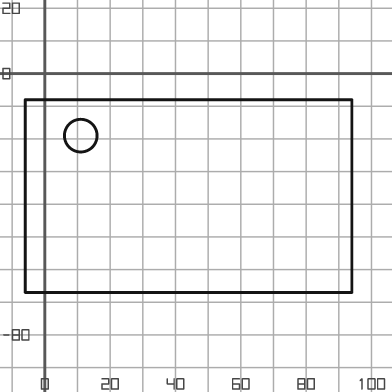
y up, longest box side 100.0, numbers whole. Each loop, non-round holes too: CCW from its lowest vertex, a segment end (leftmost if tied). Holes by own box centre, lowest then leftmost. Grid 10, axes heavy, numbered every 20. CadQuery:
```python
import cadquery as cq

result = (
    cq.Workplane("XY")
    .moveTo(-6.0, -67.0)
    .lineTo(94.0, -67.0)
    .lineTo(94.0, -8.0)
    .lineTo(-6.0, -8.0)
    .close()
    .moveTo(11.0, -19.0)
    .circle(5.0)
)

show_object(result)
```